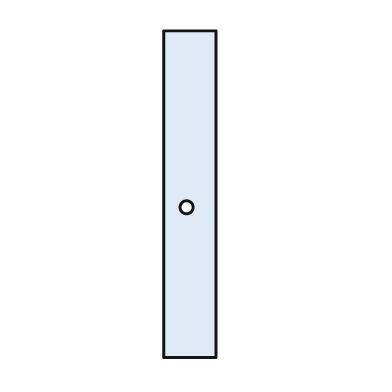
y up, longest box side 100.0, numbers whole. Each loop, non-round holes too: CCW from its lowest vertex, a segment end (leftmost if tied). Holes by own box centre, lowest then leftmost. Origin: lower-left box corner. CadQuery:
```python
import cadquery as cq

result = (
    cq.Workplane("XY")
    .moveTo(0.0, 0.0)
    .lineTo(16.0, 0.0)
    .lineTo(16.0, 100.0)
    .lineTo(0.0, 100.0)
    .close()
    .moveTo(7.0, 46.0)
    .circle(2.0)
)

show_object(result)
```